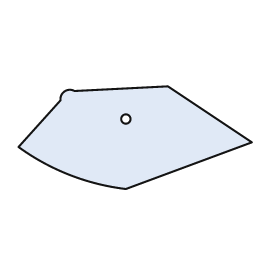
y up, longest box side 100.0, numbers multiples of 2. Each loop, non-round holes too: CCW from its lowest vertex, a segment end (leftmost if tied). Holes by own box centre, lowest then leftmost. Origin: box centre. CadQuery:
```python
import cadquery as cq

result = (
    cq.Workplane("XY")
    .moveTo(-4.0, -22.0)
    .lineTo(50.0, -2.0)
    .lineTo(14.0, 22.0)
    .lineTo(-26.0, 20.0)
    .threePointArc((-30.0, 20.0), (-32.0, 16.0))
    .lineTo(-50.0, -4.0)
    .threePointArc((-28.0, -16.0), (-4.0, -22.0))
    .close()
    .moveTo(-4.0, 8.0)
    .circle(2.0)
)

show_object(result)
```